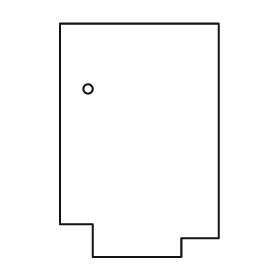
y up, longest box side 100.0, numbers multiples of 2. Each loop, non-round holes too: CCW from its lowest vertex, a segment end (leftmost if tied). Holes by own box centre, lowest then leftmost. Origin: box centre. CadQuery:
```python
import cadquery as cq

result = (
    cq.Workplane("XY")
    .moveTo(-20.0, -50.0)
    .lineTo(18.0, -50.0)
    .lineTo(18.0, -42.0)
    .lineTo(34.0, -42.0)
    .lineTo(34.0, 50.0)
    .lineTo(-34.0, 50.0)
    .lineTo(-34.0, -36.0)
    .lineTo(-20.0, -36.0)
    .close()
    .moveTo(-22.0, 22.0)
    .circle(2.0)
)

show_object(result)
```